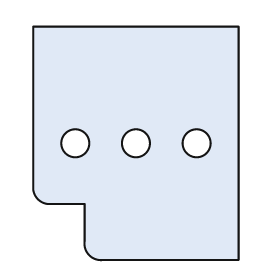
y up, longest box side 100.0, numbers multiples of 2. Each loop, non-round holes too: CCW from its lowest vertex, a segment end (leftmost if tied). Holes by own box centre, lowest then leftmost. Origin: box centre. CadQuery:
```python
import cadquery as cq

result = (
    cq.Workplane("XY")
    .moveTo(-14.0, -50.0)
    .lineTo(44.0, -50.0)
    .lineTo(44.0, 50.0)
    .lineTo(-44.0, 50.0)
    .lineTo(-44.0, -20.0)
    .threePointArc((-42.0, -24.0), (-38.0, -26.0))
    .lineTo(-22.0, -26.0)
    .lineTo(-22.0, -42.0)
    .threePointArc((-20.0, -48.0), (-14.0, -50.0))
    .close()
    .moveTo(-26.0, 0.0)
    .circle(6.0)
    .moveTo(0.0, 0.0)
    .circle(6.0)
    .moveTo(26.0, 0.0)
    .circle(6.0)
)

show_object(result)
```